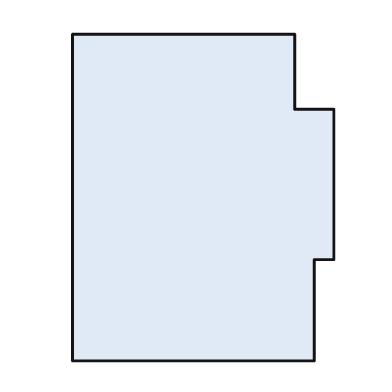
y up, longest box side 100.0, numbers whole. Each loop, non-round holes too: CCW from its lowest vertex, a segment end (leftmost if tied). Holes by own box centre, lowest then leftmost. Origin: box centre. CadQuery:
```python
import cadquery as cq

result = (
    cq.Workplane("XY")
    .moveTo(-40.0, -50.0)
    .lineTo(34.0, -50.0)
    .lineTo(34.0, -19.0)
    .lineTo(40.0, -19.0)
    .lineTo(40.0, 27.0)
    .lineTo(28.0, 27.0)
    .lineTo(28.0, 50.0)
    .lineTo(-40.0, 50.0)
    .close()
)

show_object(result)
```